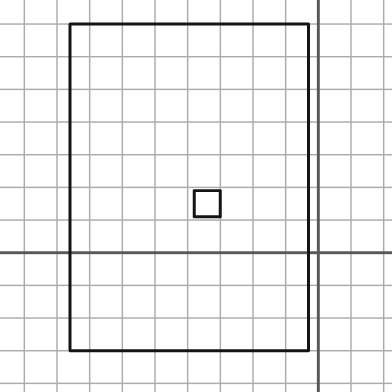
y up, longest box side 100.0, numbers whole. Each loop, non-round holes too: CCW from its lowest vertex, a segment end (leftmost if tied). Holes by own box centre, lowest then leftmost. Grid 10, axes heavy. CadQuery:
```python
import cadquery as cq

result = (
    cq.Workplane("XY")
    .moveTo(-76.0, -30.0)
    .lineTo(-3.0, -30.0)
    .lineTo(-3.0, 70.0)
    .lineTo(-76.0, 70.0)
    .close()
    .moveTo(-38.0, 11.0)
    .lineTo(-30.0, 11.0)
    .lineTo(-30.0, 19.0)
    .lineTo(-38.0, 19.0)
    .close()
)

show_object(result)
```